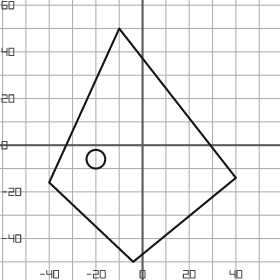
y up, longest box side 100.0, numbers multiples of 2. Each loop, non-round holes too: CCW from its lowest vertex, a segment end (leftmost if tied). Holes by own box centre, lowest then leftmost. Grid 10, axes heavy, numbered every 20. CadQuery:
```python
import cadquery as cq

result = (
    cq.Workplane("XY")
    .moveTo(-4.0, -50.0)
    .lineTo(40.0, -14.0)
    .lineTo(-10.0, 50.0)
    .lineTo(-40.0, -16.0)
    .close()
    .moveTo(-20.0, -6.0)
    .circle(4.0)
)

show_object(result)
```